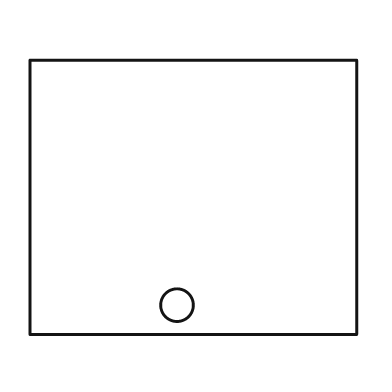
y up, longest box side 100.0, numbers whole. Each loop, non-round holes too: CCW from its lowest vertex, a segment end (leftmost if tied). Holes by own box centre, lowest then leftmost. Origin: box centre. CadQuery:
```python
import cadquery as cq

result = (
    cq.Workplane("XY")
    .moveTo(-50.0, -42.0)
    .lineTo(50.0, -42.0)
    .lineTo(50.0, 42.0)
    .lineTo(-50.0, 42.0)
    .close()
    .moveTo(-5.0, -33.0)
    .circle(5.0)
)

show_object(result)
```